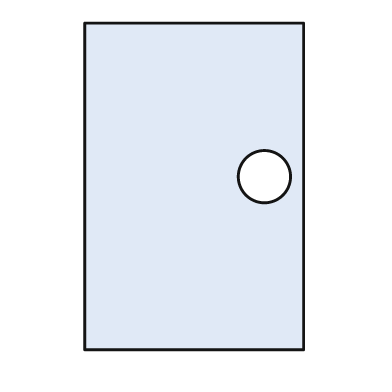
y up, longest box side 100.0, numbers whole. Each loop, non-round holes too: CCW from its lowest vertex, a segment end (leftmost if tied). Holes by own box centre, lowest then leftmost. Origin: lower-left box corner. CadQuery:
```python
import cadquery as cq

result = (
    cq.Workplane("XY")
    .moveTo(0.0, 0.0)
    .lineTo(67.0, 0.0)
    .lineTo(67.0, 100.0)
    .lineTo(0.0, 100.0)
    .close()
    .moveTo(55.0, 53.0)
    .circle(8.0)
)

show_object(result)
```